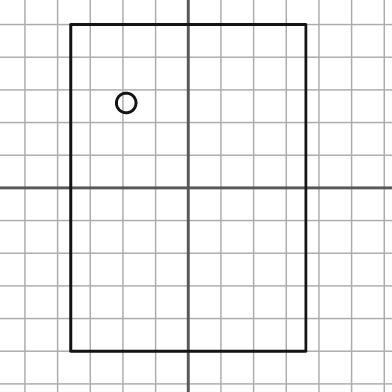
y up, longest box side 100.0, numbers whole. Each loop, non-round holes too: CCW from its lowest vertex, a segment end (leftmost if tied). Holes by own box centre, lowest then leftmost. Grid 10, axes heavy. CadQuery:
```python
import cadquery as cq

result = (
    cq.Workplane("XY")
    .moveTo(-36.0, -50.0)
    .lineTo(36.0, -50.0)
    .lineTo(36.0, 50.0)
    .lineTo(-36.0, 50.0)
    .close()
    .moveTo(-19.0, 26.0)
    .circle(3.0)
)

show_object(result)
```